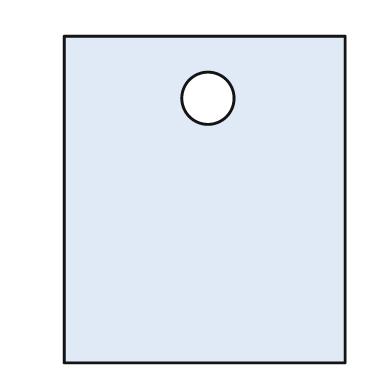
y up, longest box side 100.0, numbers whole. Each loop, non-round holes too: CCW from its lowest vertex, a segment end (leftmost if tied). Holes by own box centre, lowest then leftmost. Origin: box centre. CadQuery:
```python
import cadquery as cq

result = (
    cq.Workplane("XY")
    .moveTo(-43.0, -50.0)
    .lineTo(43.0, -50.0)
    .lineTo(43.0, 50.0)
    .lineTo(-43.0, 50.0)
    .close()
    .moveTo(1.0, 31.0)
    .circle(8.0)
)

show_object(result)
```